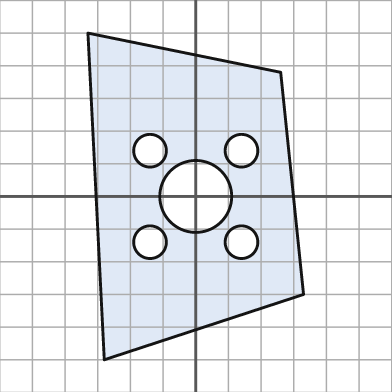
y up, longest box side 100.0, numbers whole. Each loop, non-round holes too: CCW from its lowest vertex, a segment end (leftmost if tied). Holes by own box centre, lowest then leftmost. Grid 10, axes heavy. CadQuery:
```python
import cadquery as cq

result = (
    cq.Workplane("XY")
    .moveTo(-28.0, -50.0)
    .lineTo(33.0, -30.0)
    .lineTo(26.0, 38.0)
    .lineTo(-33.0, 50.0)
    .close()
    .moveTo(-14.0, -14.0)
    .circle(5.0)
    .moveTo(14.0, -14.0)
    .circle(5.0)
    .moveTo(0.0, 0.0)
    .circle(11.0)
    .moveTo(-14.0, 14.0)
    .circle(5.0)
    .moveTo(14.0, 14.0)
    .circle(5.0)
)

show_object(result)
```